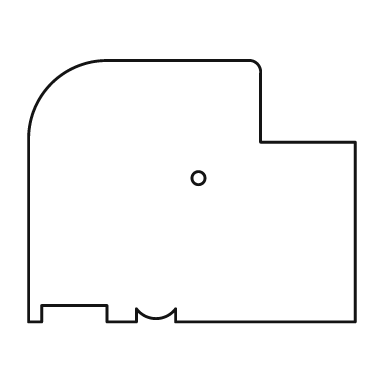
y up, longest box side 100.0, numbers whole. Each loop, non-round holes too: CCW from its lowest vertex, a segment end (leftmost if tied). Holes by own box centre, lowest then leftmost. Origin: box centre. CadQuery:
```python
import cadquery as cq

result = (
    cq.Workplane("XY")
    .moveTo(-50.0, -40.0)
    .lineTo(-46.0, -40.0)
    .lineTo(-46.0, -35.0)
    .lineTo(-26.0, -35.0)
    .lineTo(-26.0, -40.0)
    .lineTo(-17.0, -40.0)
    .lineTo(-17.0, -36.0)
    .threePointArc((-11.0, -39.0), (-5.0, -36.0))
    .lineTo(-5.0, -40.0)
    .lineTo(50.0, -40.0)
    .lineTo(50.0, 15.0)
    .lineTo(21.0, 15.0)
    .lineTo(21.0, 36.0)
    .threePointArc((20.0, 39.0), (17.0, 40.0))
    .lineTo(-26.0, 40.0)
    .threePointArc((-43.0, 33.0), (-50.0, 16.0))
    .close()
    .moveTo(2.0, 4.0)
    .circle(2.0)
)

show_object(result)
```